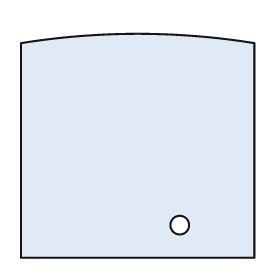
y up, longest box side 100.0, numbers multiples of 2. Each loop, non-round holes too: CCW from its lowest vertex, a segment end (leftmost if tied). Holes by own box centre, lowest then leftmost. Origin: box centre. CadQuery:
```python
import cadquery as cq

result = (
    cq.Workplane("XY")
    .moveTo(-50.0, -48.0)
    .lineTo(50.0, -48.0)
    .lineTo(50.0, 44.0)
    .threePointArc((0.0, 48.0), (-50.0, 44.0))
    .close()
    .moveTo(18.0, -34.0)
    .circle(4.0)
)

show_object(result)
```